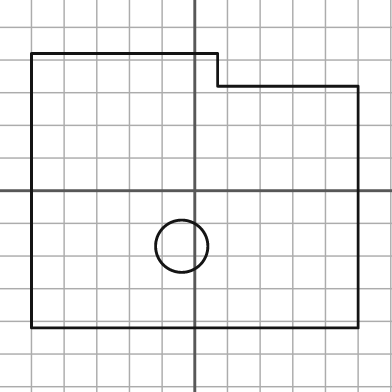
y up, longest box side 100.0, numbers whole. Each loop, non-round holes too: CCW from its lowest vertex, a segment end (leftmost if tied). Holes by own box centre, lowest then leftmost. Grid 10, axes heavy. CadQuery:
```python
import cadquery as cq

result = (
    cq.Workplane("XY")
    .moveTo(-50.0, -42.0)
    .lineTo(50.0, -42.0)
    .lineTo(50.0, 32.0)
    .lineTo(7.0, 32.0)
    .lineTo(7.0, 42.0)
    .lineTo(-50.0, 42.0)
    .close()
    .moveTo(-4.0, -17.0)
    .circle(8.0)
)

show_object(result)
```